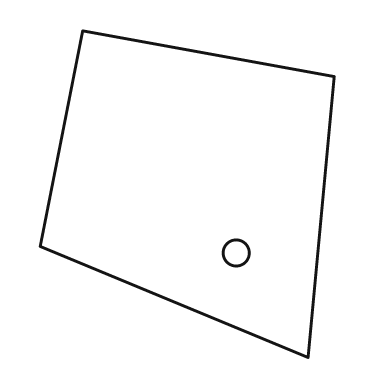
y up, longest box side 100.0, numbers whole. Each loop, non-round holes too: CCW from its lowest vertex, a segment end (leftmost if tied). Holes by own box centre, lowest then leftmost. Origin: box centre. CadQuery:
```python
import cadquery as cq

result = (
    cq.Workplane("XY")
    .moveTo(37.0, -50.0)
    .lineTo(45.0, 36.0)
    .lineTo(-32.0, 50.0)
    .lineTo(-45.0, -16.0)
    .close()
    .moveTo(15.0, -18.0)
    .circle(4.0)
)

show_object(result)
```